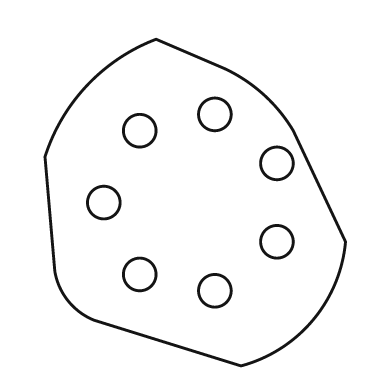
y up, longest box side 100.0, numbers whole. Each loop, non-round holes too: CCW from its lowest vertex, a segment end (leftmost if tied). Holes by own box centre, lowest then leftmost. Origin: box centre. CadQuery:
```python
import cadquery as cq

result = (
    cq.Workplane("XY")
    .moveTo(14.0, -50.0)
    .threePointArc((36.0, -36.0), (46.0, -12.0))
    .lineTo(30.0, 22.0)
    .threePointArc((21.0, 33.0), (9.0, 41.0))
    .lineTo(-12.0, 50.0)
    .threePointArc((-33.0, 36.0), (-46.0, 14.0))
    .lineTo(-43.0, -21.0)
    .threePointArc((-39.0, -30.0), (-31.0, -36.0))
    .close()
    .moveTo(6.0, -27.0)
    .circle(5.0)
    .moveTo(-17.0, -22.0)
    .circle(5.0)
    .moveTo(25.0, -12.0)
    .circle(5.0)
    .moveTo(-28.0, 0.0)
    .circle(5.0)
    .moveTo(25.0, 12.0)
    .circle(5.0)
    .moveTo(-17.0, 22.0)
    .circle(5.0)
    .moveTo(6.0, 27.0)
    .circle(5.0)
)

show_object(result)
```